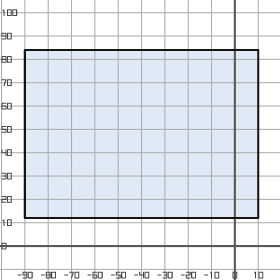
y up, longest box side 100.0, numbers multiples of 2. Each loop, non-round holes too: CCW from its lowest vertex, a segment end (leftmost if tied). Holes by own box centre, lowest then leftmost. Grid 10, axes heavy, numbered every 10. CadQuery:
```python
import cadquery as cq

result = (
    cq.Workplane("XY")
    .moveTo(-90.0, 12.0)
    .lineTo(10.0, 12.0)
    .lineTo(10.0, 84.0)
    .lineTo(-90.0, 84.0)
    .close()
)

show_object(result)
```